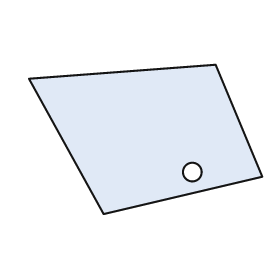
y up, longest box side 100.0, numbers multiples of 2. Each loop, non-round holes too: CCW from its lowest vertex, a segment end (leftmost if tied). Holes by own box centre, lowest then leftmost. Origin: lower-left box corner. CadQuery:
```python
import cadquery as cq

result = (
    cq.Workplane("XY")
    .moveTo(32.0, 0.0)
    .lineTo(100.0, 16.0)
    .lineTo(80.0, 64.0)
    .lineTo(0.0, 58.0)
    .close()
    .moveTo(70.0, 18.0)
    .circle(4.0)
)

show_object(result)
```